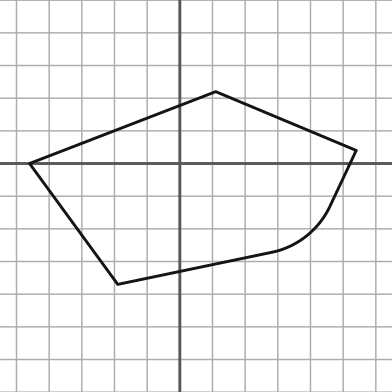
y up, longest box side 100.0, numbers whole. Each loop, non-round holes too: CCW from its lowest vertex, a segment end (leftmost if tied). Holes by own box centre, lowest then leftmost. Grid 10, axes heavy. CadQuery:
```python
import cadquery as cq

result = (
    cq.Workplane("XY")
    .moveTo(-19.0, -37.0)
    .lineTo(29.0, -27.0)
    .threePointArc((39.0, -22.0), (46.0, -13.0))
    .lineTo(54.0, 4.0)
    .lineTo(11.0, 22.0)
    .lineTo(-46.0, 0.0)
    .close()
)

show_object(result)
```